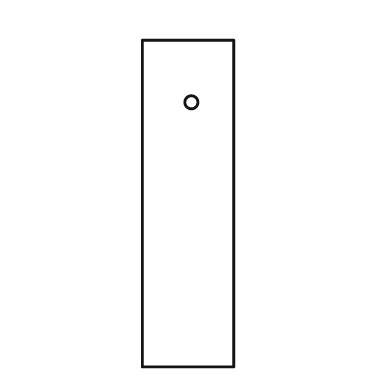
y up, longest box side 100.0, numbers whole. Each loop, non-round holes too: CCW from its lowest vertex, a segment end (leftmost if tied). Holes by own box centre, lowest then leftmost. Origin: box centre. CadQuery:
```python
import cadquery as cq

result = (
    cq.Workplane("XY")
    .moveTo(-14.0, -50.0)
    .lineTo(14.0, -50.0)
    .lineTo(14.0, 50.0)
    .lineTo(-14.0, 50.0)
    .close()
    .moveTo(1.0, 31.0)
    .circle(2.0)
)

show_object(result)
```